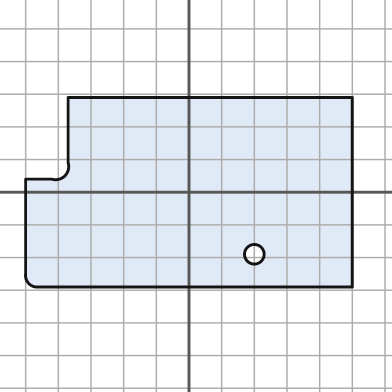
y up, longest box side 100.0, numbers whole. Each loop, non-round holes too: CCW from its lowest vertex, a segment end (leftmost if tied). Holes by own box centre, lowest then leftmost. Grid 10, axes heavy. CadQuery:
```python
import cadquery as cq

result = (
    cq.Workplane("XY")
    .moveTo(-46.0, -29.0)
    .lineTo(50.0, -29.0)
    .lineTo(50.0, 29.0)
    .lineTo(-37.0, 29.0)
    .lineTo(-37.0, 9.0)
    .threePointArc((-38.0, 5.0), (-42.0, 4.0))
    .lineTo(-50.0, 4.0)
    .lineTo(-50.0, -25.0)
    .threePointArc((-49.0, -28.0), (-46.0, -29.0))
    .close()
    .moveTo(20.0, -19.0)
    .circle(3.0)
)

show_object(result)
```